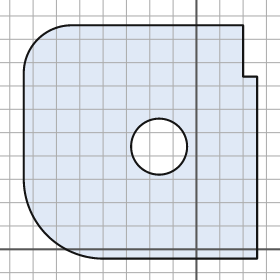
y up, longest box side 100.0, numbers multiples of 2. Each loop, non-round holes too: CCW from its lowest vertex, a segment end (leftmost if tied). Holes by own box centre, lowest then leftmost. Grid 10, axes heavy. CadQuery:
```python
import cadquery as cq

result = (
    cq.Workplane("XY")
    .moveTo(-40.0, -4.0)
    .lineTo(26.0, -4.0)
    .lineTo(26.0, 74.0)
    .lineTo(20.0, 74.0)
    .lineTo(20.0, 96.0)
    .lineTo(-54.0, 96.0)
    .threePointArc((-68.0, 90.0), (-74.0, 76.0))
    .lineTo(-74.0, 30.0)
    .threePointArc((-64.0, 6.0), (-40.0, -4.0))
    .close()
    .moveTo(-16.0, 44.0)
    .circle(12.0)
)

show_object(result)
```